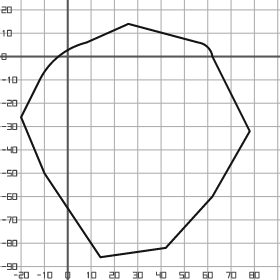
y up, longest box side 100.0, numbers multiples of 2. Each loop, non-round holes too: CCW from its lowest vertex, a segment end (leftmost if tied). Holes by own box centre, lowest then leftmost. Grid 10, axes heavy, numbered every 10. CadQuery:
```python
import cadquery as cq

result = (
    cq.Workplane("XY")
    .moveTo(14.0, -86.0)
    .lineTo(42.0, -82.0)
    .lineTo(62.0, -60.0)
    .lineTo(78.0, -32.0)
    .lineTo(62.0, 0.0)
    .threePointArc((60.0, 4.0), (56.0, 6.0))
    .lineTo(26.0, 14.0)
    .lineTo(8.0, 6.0)
    .threePointArc((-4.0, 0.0), (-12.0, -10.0))
    .lineTo(-20.0, -26.0)
    .lineTo(-10.0, -50.0)
    .close()
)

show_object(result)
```